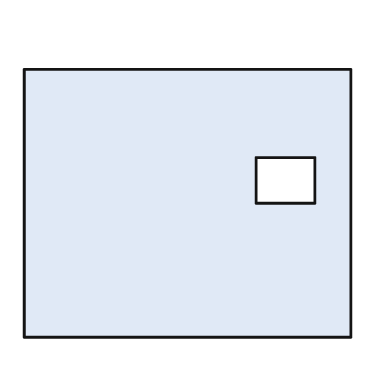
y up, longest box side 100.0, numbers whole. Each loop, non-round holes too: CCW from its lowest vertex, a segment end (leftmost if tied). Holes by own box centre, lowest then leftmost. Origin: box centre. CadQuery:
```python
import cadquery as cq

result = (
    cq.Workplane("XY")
    .moveTo(-50.0, -41.0)
    .lineTo(50.0, -41.0)
    .lineTo(50.0, 41.0)
    .lineTo(-50.0, 41.0)
    .close()
    .moveTo(21.0, 0.0)
    .lineTo(39.0, 0.0)
    .lineTo(39.0, 14.0)
    .lineTo(21.0, 14.0)
    .close()
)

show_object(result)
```